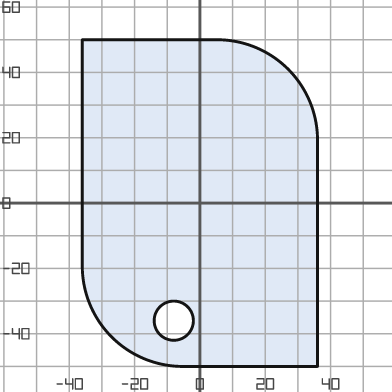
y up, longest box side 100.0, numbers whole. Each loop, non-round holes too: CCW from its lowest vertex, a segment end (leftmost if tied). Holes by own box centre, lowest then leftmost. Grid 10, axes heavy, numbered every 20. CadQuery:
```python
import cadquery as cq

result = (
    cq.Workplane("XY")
    .moveTo(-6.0, -50.0)
    .lineTo(36.0, -50.0)
    .lineTo(36.0, 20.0)
    .threePointArc((27.0, 41.0), (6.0, 50.0))
    .lineTo(-36.0, 50.0)
    .lineTo(-36.0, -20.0)
    .threePointArc((-27.0, -41.0), (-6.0, -50.0))
    .close()
    .moveTo(-8.0, -36.0)
    .circle(6.0)
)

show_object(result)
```